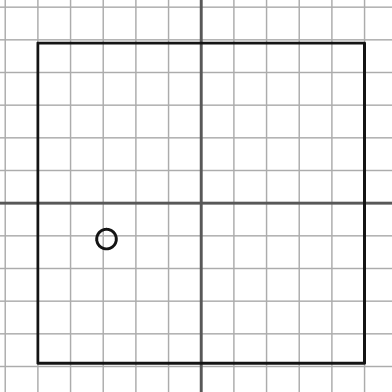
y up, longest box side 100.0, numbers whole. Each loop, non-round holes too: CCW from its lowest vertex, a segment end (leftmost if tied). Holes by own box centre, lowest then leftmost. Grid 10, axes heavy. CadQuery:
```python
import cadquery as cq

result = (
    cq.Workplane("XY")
    .moveTo(-50.0, -49.0)
    .lineTo(50.0, -49.0)
    .lineTo(50.0, 49.0)
    .lineTo(-50.0, 49.0)
    .close()
    .moveTo(-29.0, -11.0)
    .circle(3.0)
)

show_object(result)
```